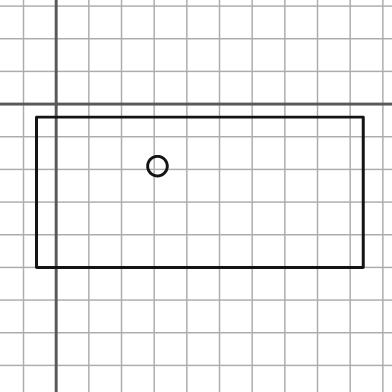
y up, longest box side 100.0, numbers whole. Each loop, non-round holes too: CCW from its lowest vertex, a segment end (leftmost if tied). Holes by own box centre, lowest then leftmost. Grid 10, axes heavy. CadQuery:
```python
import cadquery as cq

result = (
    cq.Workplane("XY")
    .moveTo(-6.0, -50.0)
    .lineTo(94.0, -50.0)
    .lineTo(94.0, -4.0)
    .lineTo(-6.0, -4.0)
    .close()
    .moveTo(31.0, -19.0)
    .circle(3.0)
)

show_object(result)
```